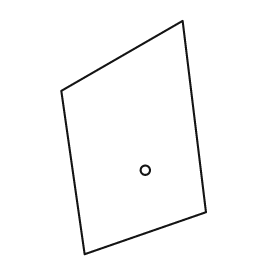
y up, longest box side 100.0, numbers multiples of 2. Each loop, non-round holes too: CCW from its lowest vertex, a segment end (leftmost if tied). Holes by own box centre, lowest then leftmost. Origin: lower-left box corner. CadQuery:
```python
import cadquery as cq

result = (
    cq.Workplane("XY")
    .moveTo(10.0, 0.0)
    .lineTo(62.0, 18.0)
    .lineTo(52.0, 100.0)
    .lineTo(0.0, 70.0)
    .close()
    .moveTo(36.0, 36.0)
    .circle(2.0)
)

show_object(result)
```